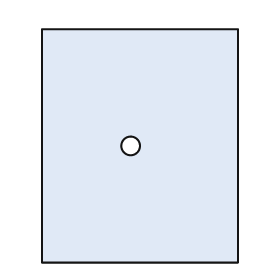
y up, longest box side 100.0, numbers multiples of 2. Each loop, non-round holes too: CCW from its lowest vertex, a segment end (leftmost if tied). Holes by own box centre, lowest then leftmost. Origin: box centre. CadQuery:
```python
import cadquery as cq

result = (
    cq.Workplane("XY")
    .moveTo(-42.0, -50.0)
    .lineTo(42.0, -50.0)
    .lineTo(42.0, 50.0)
    .lineTo(-42.0, 50.0)
    .close()
    .moveTo(-4.0, 0.0)
    .circle(4.0)
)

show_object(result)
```